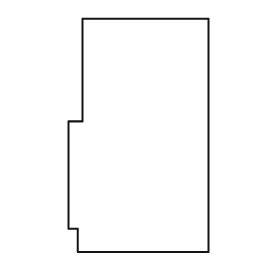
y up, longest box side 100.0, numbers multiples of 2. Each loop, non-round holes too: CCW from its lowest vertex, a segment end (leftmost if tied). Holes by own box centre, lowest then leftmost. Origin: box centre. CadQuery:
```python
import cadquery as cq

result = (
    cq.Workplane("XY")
    .moveTo(-26.0, -50.0)
    .lineTo(30.0, -50.0)
    .lineTo(30.0, 50.0)
    .lineTo(-24.0, 50.0)
    .lineTo(-24.0, 6.0)
    .lineTo(-30.0, 6.0)
    .lineTo(-30.0, -40.0)
    .lineTo(-26.0, -40.0)
    .close()
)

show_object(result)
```